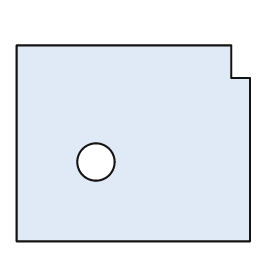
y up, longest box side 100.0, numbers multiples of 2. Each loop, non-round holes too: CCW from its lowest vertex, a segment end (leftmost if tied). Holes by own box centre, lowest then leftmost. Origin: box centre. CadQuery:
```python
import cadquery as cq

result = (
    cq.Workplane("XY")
    .moveTo(-50.0, -42.0)
    .lineTo(50.0, -42.0)
    .lineTo(50.0, 28.0)
    .lineTo(42.0, 28.0)
    .lineTo(42.0, 42.0)
    .lineTo(-50.0, 42.0)
    .close()
    .moveTo(-16.0, -8.0)
    .circle(8.0)
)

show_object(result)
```